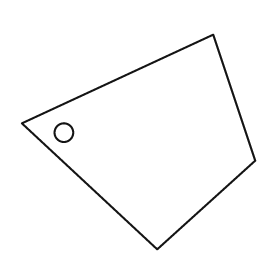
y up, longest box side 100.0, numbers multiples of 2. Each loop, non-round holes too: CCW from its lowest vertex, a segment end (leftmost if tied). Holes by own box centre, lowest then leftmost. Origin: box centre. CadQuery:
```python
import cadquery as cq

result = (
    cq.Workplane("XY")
    .moveTo(8.0, -46.0)
    .lineTo(50.0, -8.0)
    .lineTo(32.0, 46.0)
    .lineTo(-50.0, 8.0)
    .close()
    .moveTo(-32.0, 4.0)
    .circle(4.0)
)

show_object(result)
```